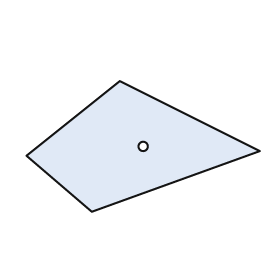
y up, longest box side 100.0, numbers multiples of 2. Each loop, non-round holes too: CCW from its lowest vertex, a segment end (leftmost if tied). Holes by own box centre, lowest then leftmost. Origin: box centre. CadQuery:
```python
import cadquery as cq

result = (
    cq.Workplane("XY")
    .moveTo(-22.0, -28.0)
    .lineTo(50.0, -2.0)
    .lineTo(-10.0, 28.0)
    .lineTo(-50.0, -4.0)
    .close()
    .moveTo(0.0, 0.0)
    .circle(2.0)
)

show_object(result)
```